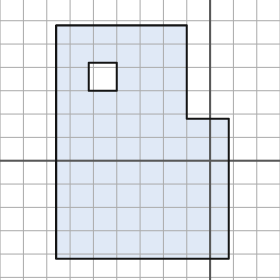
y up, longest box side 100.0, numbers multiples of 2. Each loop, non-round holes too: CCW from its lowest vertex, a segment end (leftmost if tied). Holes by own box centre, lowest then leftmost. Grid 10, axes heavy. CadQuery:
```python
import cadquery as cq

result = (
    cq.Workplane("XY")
    .moveTo(-66.0, -42.0)
    .lineTo(8.0, -42.0)
    .lineTo(8.0, 18.0)
    .lineTo(-10.0, 18.0)
    .lineTo(-10.0, 58.0)
    .lineTo(-66.0, 58.0)
    .close()
    .moveTo(-52.0, 30.0)
    .lineTo(-40.0, 30.0)
    .lineTo(-40.0, 42.0)
    .lineTo(-52.0, 42.0)
    .close()
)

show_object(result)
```